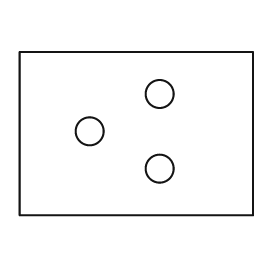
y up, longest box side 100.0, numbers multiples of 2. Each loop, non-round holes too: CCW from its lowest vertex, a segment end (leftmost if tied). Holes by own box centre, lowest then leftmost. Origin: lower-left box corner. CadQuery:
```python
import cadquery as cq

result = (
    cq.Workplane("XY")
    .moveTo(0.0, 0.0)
    .lineTo(100.0, 0.0)
    .lineTo(100.0, 70.0)
    .lineTo(0.0, 70.0)
    .close()
    .moveTo(60.0, 20.0)
    .circle(6.0)
    .moveTo(30.0, 36.0)
    .circle(6.0)
    .moveTo(60.0, 52.0)
    .circle(6.0)
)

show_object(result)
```